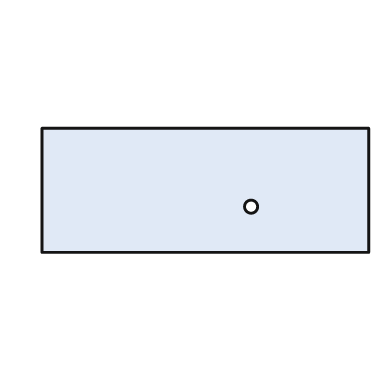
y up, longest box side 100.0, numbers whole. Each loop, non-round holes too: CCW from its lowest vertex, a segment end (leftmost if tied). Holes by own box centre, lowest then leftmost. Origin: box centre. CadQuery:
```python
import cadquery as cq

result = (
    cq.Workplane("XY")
    .moveTo(-50.0, -19.0)
    .lineTo(50.0, -19.0)
    .lineTo(50.0, 19.0)
    .lineTo(-50.0, 19.0)
    .close()
    .moveTo(14.0, -5.0)
    .circle(2.0)
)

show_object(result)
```